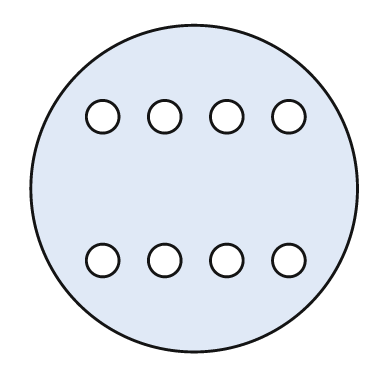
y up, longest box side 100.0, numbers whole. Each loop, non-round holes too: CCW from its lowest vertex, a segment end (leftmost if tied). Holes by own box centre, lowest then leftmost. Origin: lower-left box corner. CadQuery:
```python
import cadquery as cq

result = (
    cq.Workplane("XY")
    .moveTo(50.0, 50.0)
    .circle(50.0)
    .moveTo(22.0, 28.0)
    .circle(5.0)
    .moveTo(41.0, 28.0)
    .circle(5.0)
    .moveTo(60.0, 28.0)
    .circle(5.0)
    .moveTo(79.0, 28.0)
    .circle(5.0)
    .moveTo(22.0, 72.0)
    .circle(5.0)
    .moveTo(41.0, 72.0)
    .circle(5.0)
    .moveTo(60.0, 72.0)
    .circle(5.0)
    .moveTo(79.0, 72.0)
    .circle(5.0)
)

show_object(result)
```